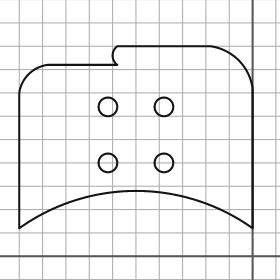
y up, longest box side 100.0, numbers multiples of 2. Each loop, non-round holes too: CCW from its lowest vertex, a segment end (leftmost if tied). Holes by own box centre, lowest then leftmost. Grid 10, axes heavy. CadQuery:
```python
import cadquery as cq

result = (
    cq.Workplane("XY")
    .moveTo(-100.0, 12.0)
    .threePointArc((-50.0, 28.0), (0.0, 12.0))
    .lineTo(0.0, 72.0)
    .threePointArc((-6.0, 84.0), (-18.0, 90.0))
    .lineTo(-58.0, 90.0)
    .threePointArc((-60.0, 86.0), (-58.0, 82.0))
    .lineTo(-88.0, 82.0)
    .threePointArc((-96.0, 78.0), (-100.0, 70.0))
    .close()
    .moveTo(-62.0, 40.0)
    .circle(4.0)
    .moveTo(-38.0, 40.0)
    .circle(4.0)
    .moveTo(-62.0, 64.0)
    .circle(4.0)
    .moveTo(-38.0, 64.0)
    .circle(4.0)
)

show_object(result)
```